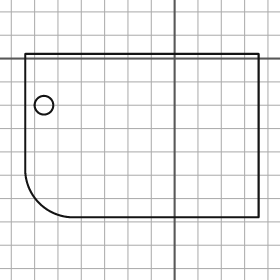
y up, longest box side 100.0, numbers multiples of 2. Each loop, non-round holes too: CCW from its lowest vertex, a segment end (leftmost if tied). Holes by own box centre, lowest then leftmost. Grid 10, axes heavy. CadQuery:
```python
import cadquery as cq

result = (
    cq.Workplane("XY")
    .moveTo(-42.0, -68.0)
    .lineTo(36.0, -68.0)
    .lineTo(36.0, 2.0)
    .lineTo(-64.0, 2.0)
    .lineTo(-64.0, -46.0)
    .threePointArc((-58.0, -62.0), (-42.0, -68.0))
    .close()
    .moveTo(-56.0, -20.0)
    .circle(4.0)
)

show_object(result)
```